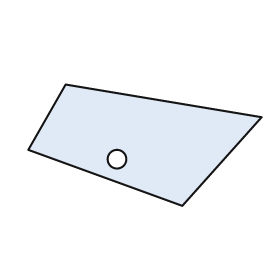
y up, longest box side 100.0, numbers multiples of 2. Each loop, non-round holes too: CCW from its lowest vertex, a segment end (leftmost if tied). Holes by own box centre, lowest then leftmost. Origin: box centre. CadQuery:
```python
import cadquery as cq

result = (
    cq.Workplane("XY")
    .moveTo(16.0, -26.0)
    .lineTo(50.0, 12.0)
    .lineTo(-34.0, 26.0)
    .lineTo(-50.0, -2.0)
    .close()
    .moveTo(-12.0, -6.0)
    .circle(4.0)
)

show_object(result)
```